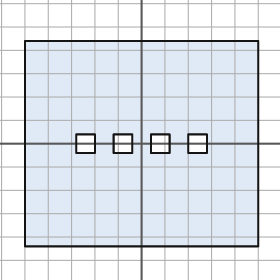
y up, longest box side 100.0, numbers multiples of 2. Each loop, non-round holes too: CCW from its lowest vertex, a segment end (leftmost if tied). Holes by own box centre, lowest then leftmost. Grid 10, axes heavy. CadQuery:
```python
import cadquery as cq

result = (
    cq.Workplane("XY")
    .moveTo(-50.0, -44.0)
    .lineTo(50.0, -44.0)
    .lineTo(50.0, 44.0)
    .lineTo(-50.0, 44.0)
    .close()
    .moveTo(-28.0, -4.0)
    .lineTo(-20.0, -4.0)
    .lineTo(-20.0, 4.0)
    .lineTo(-28.0, 4.0)
    .close()
    .moveTo(-12.0, -4.0)
    .lineTo(-4.0, -4.0)
    .lineTo(-4.0, 4.0)
    .lineTo(-12.0, 4.0)
    .close()
    .moveTo(4.0, -4.0)
    .lineTo(12.0, -4.0)
    .lineTo(12.0, 4.0)
    .lineTo(4.0, 4.0)
    .close()
    .moveTo(20.0, -4.0)
    .lineTo(28.0, -4.0)
    .lineTo(28.0, 4.0)
    .lineTo(20.0, 4.0)
    .close()
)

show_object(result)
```